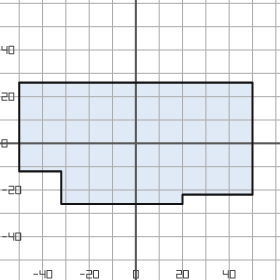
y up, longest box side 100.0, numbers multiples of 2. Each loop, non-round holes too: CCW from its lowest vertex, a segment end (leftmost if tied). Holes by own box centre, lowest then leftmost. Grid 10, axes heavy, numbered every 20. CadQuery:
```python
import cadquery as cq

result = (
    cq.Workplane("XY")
    .moveTo(-32.0, -26.0)
    .lineTo(20.0, -26.0)
    .lineTo(20.0, -22.0)
    .lineTo(50.0, -22.0)
    .lineTo(50.0, 26.0)
    .lineTo(-50.0, 26.0)
    .lineTo(-50.0, -12.0)
    .lineTo(-32.0, -12.0)
    .close()
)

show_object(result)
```